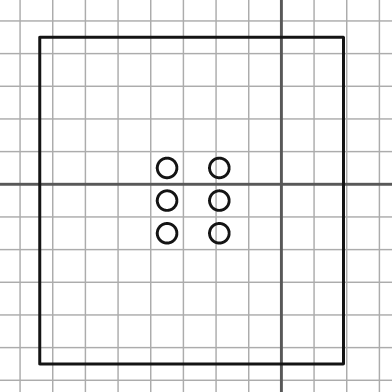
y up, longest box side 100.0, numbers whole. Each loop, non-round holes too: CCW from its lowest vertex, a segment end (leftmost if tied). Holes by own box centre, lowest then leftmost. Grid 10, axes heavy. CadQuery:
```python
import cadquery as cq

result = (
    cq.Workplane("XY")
    .moveTo(-74.0, -55.0)
    .lineTo(19.0, -55.0)
    .lineTo(19.0, 45.0)
    .lineTo(-74.0, 45.0)
    .close()
    .moveTo(-35.0, -15.0)
    .circle(3.0)
    .moveTo(-19.0, -15.0)
    .circle(3.0)
    .moveTo(-35.0, -5.0)
    .circle(3.0)
    .moveTo(-19.0, -5.0)
    .circle(3.0)
    .moveTo(-35.0, 5.0)
    .circle(3.0)
    .moveTo(-19.0, 5.0)
    .circle(3.0)
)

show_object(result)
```